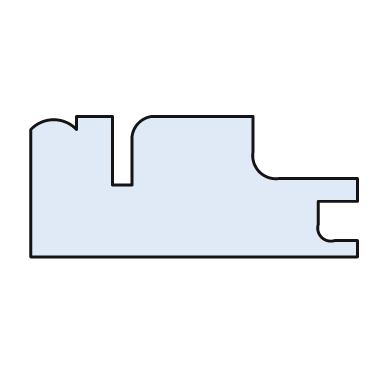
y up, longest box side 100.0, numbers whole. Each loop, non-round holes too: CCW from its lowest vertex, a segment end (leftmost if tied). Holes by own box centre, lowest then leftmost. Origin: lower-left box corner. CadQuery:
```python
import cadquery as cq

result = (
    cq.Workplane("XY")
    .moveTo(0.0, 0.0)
    .lineTo(100.0, 0.0)
    .lineTo(100.0, 5.0)
    .lineTo(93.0, 5.0)
    .threePointArc((89.0, 6.0), (88.0, 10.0))
    .lineTo(88.0, 17.0)
    .lineTo(100.0, 17.0)
    .lineTo(100.0, 24.0)
    .lineTo(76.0, 24.0)
    .threePointArc((70.0, 26.0), (68.0, 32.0))
    .lineTo(68.0, 43.0)
    .lineTo(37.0, 43.0)
    .threePointArc((33.0, 41.0), (31.0, 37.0))
    .lineTo(31.0, 22.0)
    .lineTo(25.0, 22.0)
    .lineTo(25.0, 43.0)
    .lineTo(14.0, 43.0)
    .lineTo(14.0, 39.0)
    .threePointArc((7.0, 42.0), (0.0, 39.0))
    .close()
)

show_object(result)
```